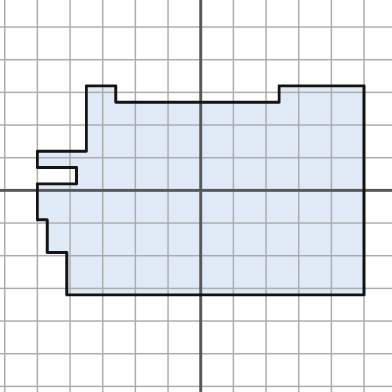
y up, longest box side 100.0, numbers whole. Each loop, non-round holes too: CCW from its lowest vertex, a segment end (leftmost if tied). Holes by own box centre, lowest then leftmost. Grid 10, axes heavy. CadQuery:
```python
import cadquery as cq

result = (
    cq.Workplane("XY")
    .moveTo(-41.0, -32.0)
    .lineTo(50.0, -32.0)
    .lineTo(50.0, 32.0)
    .lineTo(24.0, 32.0)
    .lineTo(24.0, 27.0)
    .lineTo(-26.0, 27.0)
    .lineTo(-26.0, 32.0)
    .lineTo(-35.0, 32.0)
    .lineTo(-35.0, 12.0)
    .lineTo(-50.0, 12.0)
    .lineTo(-50.0, 7.0)
    .lineTo(-38.0, 7.0)
    .lineTo(-38.0, 2.0)
    .lineTo(-50.0, 2.0)
    .lineTo(-50.0, -9.0)
    .lineTo(-47.0, -9.0)
    .lineTo(-47.0, -19.0)
    .lineTo(-41.0, -19.0)
    .close()
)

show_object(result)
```